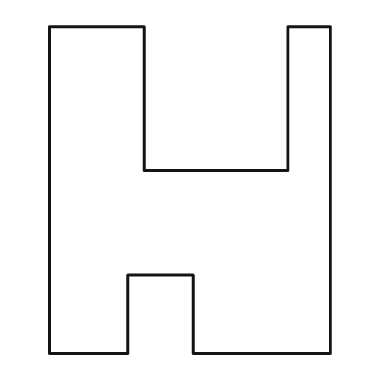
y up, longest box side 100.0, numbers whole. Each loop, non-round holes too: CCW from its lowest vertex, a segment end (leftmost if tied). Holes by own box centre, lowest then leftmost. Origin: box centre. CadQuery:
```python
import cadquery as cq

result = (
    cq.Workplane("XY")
    .moveTo(-43.0, -50.0)
    .lineTo(-19.0, -50.0)
    .lineTo(-19.0, -26.0)
    .lineTo(1.0, -26.0)
    .lineTo(1.0, -50.0)
    .lineTo(43.0, -50.0)
    .lineTo(43.0, 50.0)
    .lineTo(30.0, 50.0)
    .lineTo(30.0, 6.0)
    .lineTo(-14.0, 6.0)
    .lineTo(-14.0, 50.0)
    .lineTo(-43.0, 50.0)
    .close()
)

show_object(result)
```